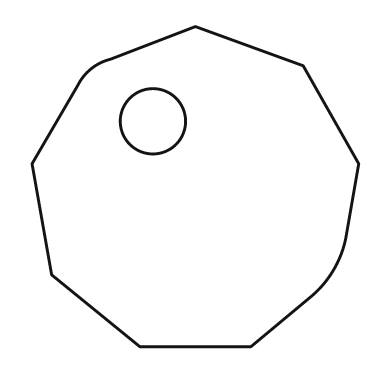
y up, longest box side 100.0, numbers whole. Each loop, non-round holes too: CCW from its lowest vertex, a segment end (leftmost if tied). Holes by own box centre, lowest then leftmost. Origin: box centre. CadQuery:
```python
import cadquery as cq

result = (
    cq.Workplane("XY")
    .moveTo(-17.0, -49.0)
    .lineTo(17.0, -49.0)
    .lineTo(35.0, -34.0)
    .threePointArc((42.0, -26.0), (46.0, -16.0))
    .lineTo(50.0, 7.0)
    .lineTo(33.0, 37.0)
    .lineTo(0.0, 49.0)
    .lineTo(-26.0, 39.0)
    .threePointArc((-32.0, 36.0), (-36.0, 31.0))
    .lineTo(-50.0, 7.0)
    .lineTo(-44.0, -27.0)
    .close()
    .moveTo(-13.0, 20.0)
    .circle(10.0)
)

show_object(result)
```